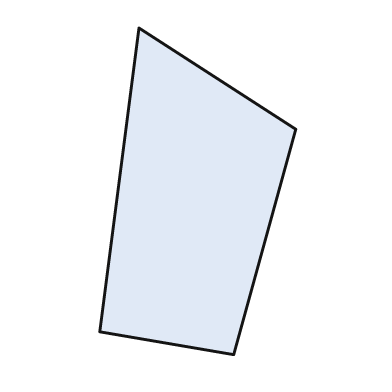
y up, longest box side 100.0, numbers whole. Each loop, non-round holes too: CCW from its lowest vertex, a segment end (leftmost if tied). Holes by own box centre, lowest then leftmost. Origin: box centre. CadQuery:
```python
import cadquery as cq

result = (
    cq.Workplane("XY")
    .moveTo(11.0, -50.0)
    .lineTo(30.0, 19.0)
    .lineTo(-18.0, 50.0)
    .lineTo(-30.0, -43.0)
    .close()
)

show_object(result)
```